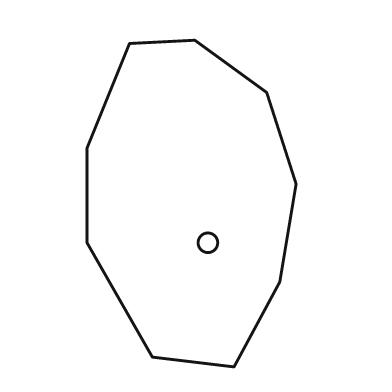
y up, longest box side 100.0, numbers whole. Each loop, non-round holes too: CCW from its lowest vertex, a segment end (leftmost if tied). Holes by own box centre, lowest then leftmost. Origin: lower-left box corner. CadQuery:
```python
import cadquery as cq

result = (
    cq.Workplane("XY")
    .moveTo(45.0, 0.0)
    .lineTo(59.0, 26.0)
    .lineTo(64.0, 56.0)
    .lineTo(55.0, 84.0)
    .lineTo(33.0, 100.0)
    .lineTo(13.0, 99.0)
    .lineTo(0.0, 67.0)
    .lineTo(0.0, 38.0)
    .lineTo(20.0, 3.0)
    .close()
    .moveTo(37.0, 38.0)
    .circle(3.0)
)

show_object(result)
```